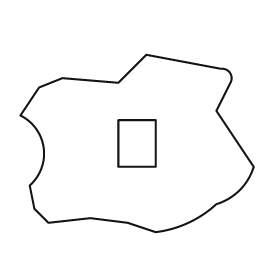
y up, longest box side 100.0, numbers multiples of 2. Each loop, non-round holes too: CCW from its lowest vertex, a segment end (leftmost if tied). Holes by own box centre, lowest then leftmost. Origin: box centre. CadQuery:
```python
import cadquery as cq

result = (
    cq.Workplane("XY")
    .moveTo(8.0, -38.0)
    .threePointArc((22.0, -34.0), (34.0, -26.0))
    .threePointArc((44.0, -20.0), (50.0, -10.0))
    .lineTo(34.0, 14.0)
    .lineTo(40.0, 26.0)
    .threePointArc((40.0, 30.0), (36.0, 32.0))
    .lineTo(4.0, 38.0)
    .lineTo(-8.0, 26.0)
    .lineTo(-32.0, 28.0)
    .lineTo(-42.0, 24.0)
    .lineTo(-50.0, 12.0)
    .threePointArc((-40.0, -2.0), (-46.0, -18.0))
    .lineTo(-44.0, -28.0)
    .lineTo(-38.0, -34.0)
    .lineTo(-20.0, -32.0)
    .lineTo(-4.0, -34.0)
    .close()
    .moveTo(-8.0, -10.0)
    .lineTo(8.0, -10.0)
    .lineTo(8.0, 10.0)
    .lineTo(-8.0, 10.0)
    .close()
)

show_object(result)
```